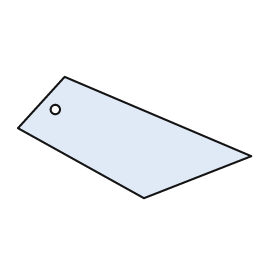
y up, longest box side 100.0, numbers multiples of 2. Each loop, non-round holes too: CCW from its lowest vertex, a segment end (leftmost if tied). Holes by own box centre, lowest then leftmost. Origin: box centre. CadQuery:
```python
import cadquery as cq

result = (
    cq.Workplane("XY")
    .moveTo(4.0, -26.0)
    .lineTo(50.0, -8.0)
    .lineTo(-30.0, 26.0)
    .lineTo(-50.0, 4.0)
    .close()
    .moveTo(-34.0, 12.0)
    .circle(2.0)
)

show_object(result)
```